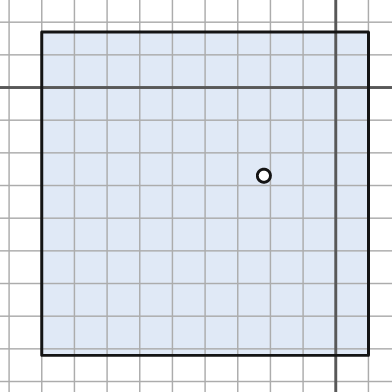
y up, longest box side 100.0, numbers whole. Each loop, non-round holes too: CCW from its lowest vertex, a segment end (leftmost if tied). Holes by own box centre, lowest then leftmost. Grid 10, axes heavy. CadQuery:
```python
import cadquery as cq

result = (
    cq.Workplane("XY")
    .moveTo(-90.0, -82.0)
    .lineTo(10.0, -82.0)
    .lineTo(10.0, 17.0)
    .lineTo(-90.0, 17.0)
    .close()
    .moveTo(-22.0, -27.0)
    .circle(2.0)
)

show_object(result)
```